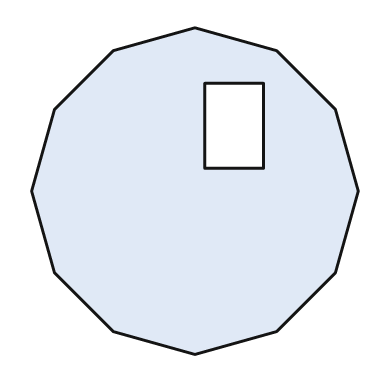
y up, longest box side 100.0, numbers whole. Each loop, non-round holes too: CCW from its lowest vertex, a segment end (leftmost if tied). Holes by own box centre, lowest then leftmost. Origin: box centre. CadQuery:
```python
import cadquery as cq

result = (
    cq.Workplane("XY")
    .moveTo(0.0, -50.0)
    .lineTo(25.0, -43.0)
    .lineTo(43.0, -25.0)
    .lineTo(50.0, 0.0)
    .lineTo(43.0, 25.0)
    .lineTo(25.0, 43.0)
    .lineTo(0.0, 50.0)
    .lineTo(-25.0, 43.0)
    .lineTo(-43.0, 25.0)
    .lineTo(-50.0, 0.0)
    .lineTo(-43.0, -25.0)
    .lineTo(-25.0, -43.0)
    .close()
    .moveTo(3.0, 7.0)
    .lineTo(21.0, 7.0)
    .lineTo(21.0, 33.0)
    .lineTo(3.0, 33.0)
    .close()
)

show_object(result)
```